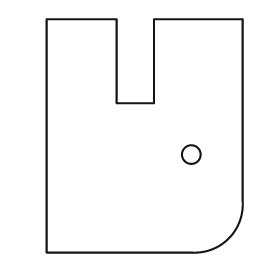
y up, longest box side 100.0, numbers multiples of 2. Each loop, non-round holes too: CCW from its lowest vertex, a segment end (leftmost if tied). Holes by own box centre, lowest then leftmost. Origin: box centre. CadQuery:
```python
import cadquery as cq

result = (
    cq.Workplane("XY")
    .moveTo(-42.0, -50.0)
    .lineTo(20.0, -50.0)
    .threePointArc((36.0, -44.0), (42.0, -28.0))
    .lineTo(42.0, 50.0)
    .lineTo(4.0, 50.0)
    .lineTo(4.0, 14.0)
    .lineTo(-12.0, 14.0)
    .lineTo(-12.0, 50.0)
    .lineTo(-42.0, 50.0)
    .close()
    .moveTo(20.0, -8.0)
    .circle(4.0)
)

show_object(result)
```